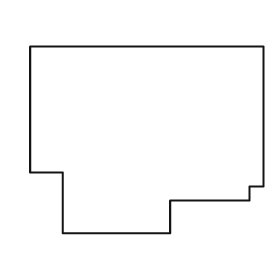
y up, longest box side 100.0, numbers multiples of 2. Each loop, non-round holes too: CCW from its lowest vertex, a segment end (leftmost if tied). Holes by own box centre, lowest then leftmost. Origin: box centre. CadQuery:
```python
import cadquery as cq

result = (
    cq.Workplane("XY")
    .moveTo(-36.0, -40.0)
    .lineTo(10.0, -40.0)
    .lineTo(10.0, -26.0)
    .lineTo(44.0, -26.0)
    .lineTo(44.0, -20.0)
    .lineTo(50.0, -20.0)
    .lineTo(50.0, 40.0)
    .lineTo(-50.0, 40.0)
    .lineTo(-50.0, -14.0)
    .lineTo(-36.0, -14.0)
    .close()
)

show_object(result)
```